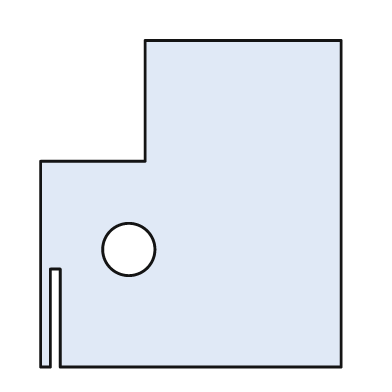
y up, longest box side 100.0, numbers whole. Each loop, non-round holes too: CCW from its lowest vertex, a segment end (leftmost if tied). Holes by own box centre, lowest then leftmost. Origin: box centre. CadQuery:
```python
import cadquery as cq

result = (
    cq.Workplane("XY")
    .moveTo(-46.0, -50.0)
    .lineTo(-43.0, -50.0)
    .lineTo(-43.0, -20.0)
    .lineTo(-40.0, -20.0)
    .lineTo(-40.0, -50.0)
    .lineTo(46.0, -50.0)
    .lineTo(46.0, 50.0)
    .lineTo(-14.0, 50.0)
    .lineTo(-14.0, 13.0)
    .lineTo(-46.0, 13.0)
    .close()
    .moveTo(-19.0, -14.0)
    .circle(8.0)
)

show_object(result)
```